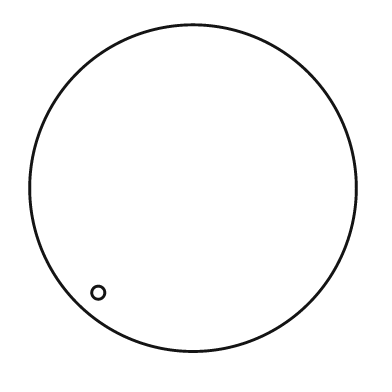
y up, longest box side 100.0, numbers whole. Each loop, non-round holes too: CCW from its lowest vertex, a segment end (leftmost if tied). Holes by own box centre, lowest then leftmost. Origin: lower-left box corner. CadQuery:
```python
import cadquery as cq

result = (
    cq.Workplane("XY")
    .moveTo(50.0, 50.0)
    .circle(50.0)
    .moveTo(21.0, 18.0)
    .circle(2.0)
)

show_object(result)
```